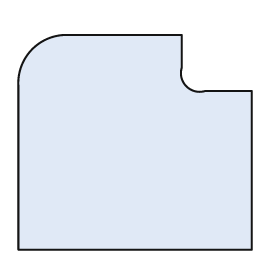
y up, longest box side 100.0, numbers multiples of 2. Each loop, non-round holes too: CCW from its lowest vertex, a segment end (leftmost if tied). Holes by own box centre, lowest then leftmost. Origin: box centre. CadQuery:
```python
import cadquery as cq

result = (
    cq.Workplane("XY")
    .moveTo(-50.0, -46.0)
    .lineTo(50.0, -46.0)
    .lineTo(50.0, 22.0)
    .lineTo(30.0, 22.0)
    .threePointArc((22.0, 24.0), (20.0, 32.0))
    .lineTo(20.0, 46.0)
    .lineTo(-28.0, 46.0)
    .threePointArc((-44.0, 40.0), (-50.0, 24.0))
    .close()
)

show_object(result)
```